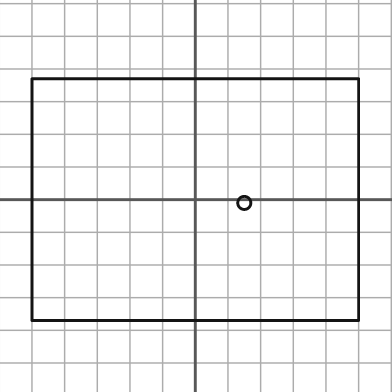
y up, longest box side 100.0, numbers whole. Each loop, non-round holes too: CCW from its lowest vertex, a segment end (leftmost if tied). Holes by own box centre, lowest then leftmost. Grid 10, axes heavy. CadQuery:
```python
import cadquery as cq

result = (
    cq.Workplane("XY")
    .moveTo(-50.0, -37.0)
    .lineTo(50.0, -37.0)
    .lineTo(50.0, 37.0)
    .lineTo(-50.0, 37.0)
    .close()
    .moveTo(15.0, -1.0)
    .circle(2.0)
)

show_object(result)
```